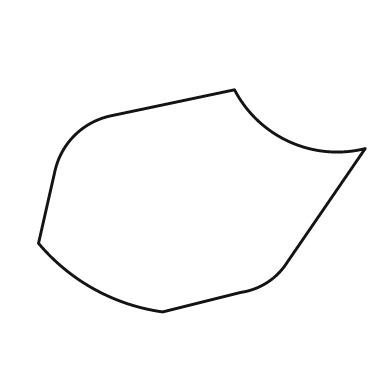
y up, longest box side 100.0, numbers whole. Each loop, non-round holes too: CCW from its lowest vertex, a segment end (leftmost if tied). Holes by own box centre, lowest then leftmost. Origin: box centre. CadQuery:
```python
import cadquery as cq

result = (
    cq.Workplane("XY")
    .moveTo(-12.0, -34.0)
    .lineTo(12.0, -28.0)
    .threePointArc((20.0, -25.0), (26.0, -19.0))
    .lineTo(50.0, 16.0)
    .threePointArc((27.0, 18.0), (10.0, 34.0))
    .lineTo(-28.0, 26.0)
    .threePointArc((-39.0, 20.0), (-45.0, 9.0))
    .lineTo(-50.0, -13.0)
    .threePointArc((-33.0, -27.0), (-12.0, -34.0))
    .close()
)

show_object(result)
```